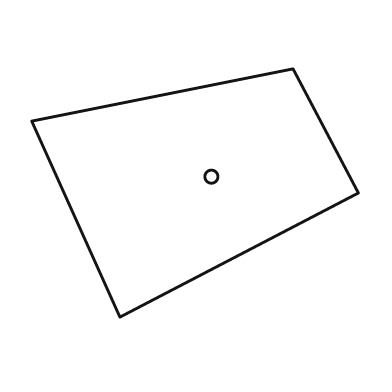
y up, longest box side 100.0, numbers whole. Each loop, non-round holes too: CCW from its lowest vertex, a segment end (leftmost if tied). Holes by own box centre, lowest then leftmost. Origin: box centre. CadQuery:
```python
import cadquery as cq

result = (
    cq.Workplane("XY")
    .moveTo(-23.0, -38.0)
    .lineTo(50.0, 0.0)
    .lineTo(30.0, 38.0)
    .lineTo(-50.0, 22.0)
    .close()
    .moveTo(5.0, 5.0)
    .circle(2.0)
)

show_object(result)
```